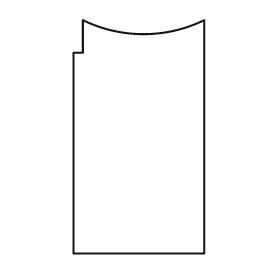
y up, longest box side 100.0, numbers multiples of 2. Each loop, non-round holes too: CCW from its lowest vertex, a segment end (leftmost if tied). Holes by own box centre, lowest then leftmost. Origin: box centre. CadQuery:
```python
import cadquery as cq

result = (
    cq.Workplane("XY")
    .moveTo(-28.0, -50.0)
    .lineTo(28.0, -50.0)
    .lineTo(28.0, 50.0)
    .threePointArc((2.0, 44.0), (-24.0, 50.0))
    .lineTo(-24.0, 36.0)
    .lineTo(-28.0, 36.0)
    .close()
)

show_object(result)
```